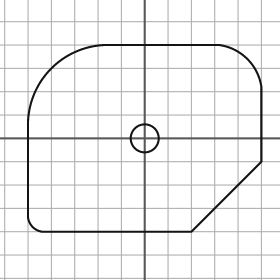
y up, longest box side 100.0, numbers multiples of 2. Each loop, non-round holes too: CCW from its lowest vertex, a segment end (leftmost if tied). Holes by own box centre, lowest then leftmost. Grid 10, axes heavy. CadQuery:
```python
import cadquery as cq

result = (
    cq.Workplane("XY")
    .moveTo(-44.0, -40.0)
    .lineTo(20.0, -40.0)
    .lineTo(50.0, -10.0)
    .lineTo(50.0, 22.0)
    .threePointArc((44.0, 34.0), (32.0, 40.0))
    .lineTo(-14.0, 40.0)
    .threePointArc((-40.0, 30.0), (-50.0, 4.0))
    .lineTo(-50.0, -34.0)
    .threePointArc((-48.0, -38.0), (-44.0, -40.0))
    .close()
    .moveTo(0.0, 0.0)
    .circle(6.0)
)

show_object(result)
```